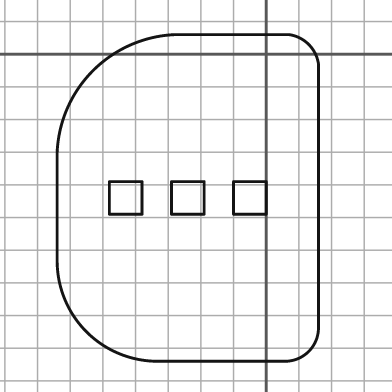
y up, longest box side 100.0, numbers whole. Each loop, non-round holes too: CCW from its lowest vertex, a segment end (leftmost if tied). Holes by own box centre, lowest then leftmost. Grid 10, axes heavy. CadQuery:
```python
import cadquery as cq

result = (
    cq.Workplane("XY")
    .moveTo(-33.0, -94.0)
    .lineTo(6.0, -94.0)
    .threePointArc((13.0, -91.0), (16.0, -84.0))
    .lineTo(16.0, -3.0)
    .threePointArc((13.0, 3.0), (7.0, 6.0))
    .lineTo(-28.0, 6.0)
    .threePointArc((-53.0, -5.0), (-64.0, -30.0))
    .lineTo(-64.0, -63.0)
    .threePointArc((-55.0, -85.0), (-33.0, -94.0))
    .close()
    .moveTo(-48.0, -49.0)
    .lineTo(-38.0, -49.0)
    .lineTo(-38.0, -39.0)
    .lineTo(-48.0, -39.0)
    .close()
    .moveTo(-29.0, -49.0)
    .lineTo(-19.0, -49.0)
    .lineTo(-19.0, -39.0)
    .lineTo(-29.0, -39.0)
    .close()
    .moveTo(-10.0, -49.0)
    .lineTo(0.0, -49.0)
    .lineTo(0.0, -39.0)
    .lineTo(-10.0, -39.0)
    .close()
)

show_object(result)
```